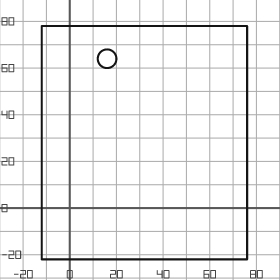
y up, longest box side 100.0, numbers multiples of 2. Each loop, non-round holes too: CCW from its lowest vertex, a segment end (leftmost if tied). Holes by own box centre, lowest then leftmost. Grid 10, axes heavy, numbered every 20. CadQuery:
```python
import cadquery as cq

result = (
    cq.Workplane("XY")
    .moveTo(-12.0, -22.0)
    .lineTo(76.0, -22.0)
    .lineTo(76.0, 78.0)
    .lineTo(-12.0, 78.0)
    .close()
    .moveTo(16.0, 64.0)
    .circle(4.0)
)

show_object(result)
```